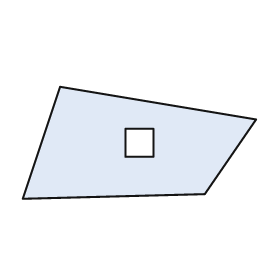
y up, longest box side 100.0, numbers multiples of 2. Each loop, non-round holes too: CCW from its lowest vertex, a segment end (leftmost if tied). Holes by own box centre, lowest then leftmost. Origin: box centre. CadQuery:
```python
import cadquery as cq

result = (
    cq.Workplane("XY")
    .moveTo(-50.0, -24.0)
    .lineTo(28.0, -22.0)
    .lineTo(50.0, 10.0)
    .lineTo(-34.0, 24.0)
    .close()
    .moveTo(-6.0, -6.0)
    .lineTo(6.0, -6.0)
    .lineTo(6.0, 6.0)
    .lineTo(-6.0, 6.0)
    .close()
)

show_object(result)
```